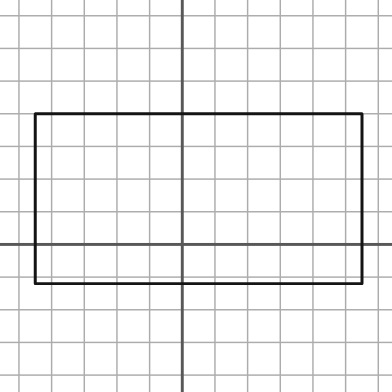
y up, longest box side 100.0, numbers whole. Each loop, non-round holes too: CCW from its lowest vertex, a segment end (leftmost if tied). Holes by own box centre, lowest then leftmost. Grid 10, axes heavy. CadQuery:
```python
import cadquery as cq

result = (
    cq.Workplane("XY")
    .moveTo(-45.0, -12.0)
    .lineTo(55.0, -12.0)
    .lineTo(55.0, 40.0)
    .lineTo(-45.0, 40.0)
    .close()
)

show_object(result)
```